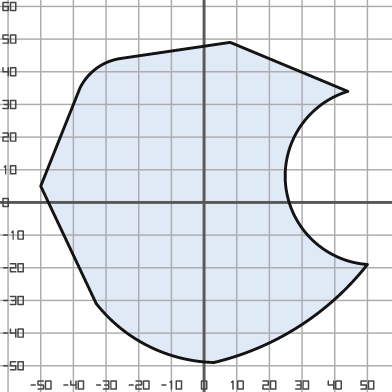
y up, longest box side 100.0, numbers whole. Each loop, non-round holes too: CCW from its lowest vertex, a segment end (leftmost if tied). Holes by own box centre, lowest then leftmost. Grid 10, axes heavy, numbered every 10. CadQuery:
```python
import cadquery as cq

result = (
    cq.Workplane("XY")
    .moveTo(3.0, -49.0)
    .threePointArc((29.0, -38.0), (50.0, -19.0))
    .threePointArc((25.0, 5.0), (44.0, 34.0))
    .lineTo(8.0, 49.0)
    .lineTo(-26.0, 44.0)
    .threePointArc((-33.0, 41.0), (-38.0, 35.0))
    .lineTo(-50.0, 5.0)
    .lineTo(-33.0, -31.0)
    .threePointArc((-17.0, -44.0), (3.0, -49.0))
    .close()
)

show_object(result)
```